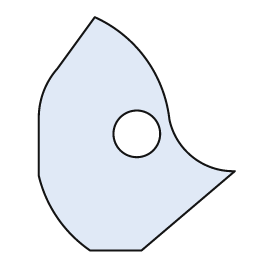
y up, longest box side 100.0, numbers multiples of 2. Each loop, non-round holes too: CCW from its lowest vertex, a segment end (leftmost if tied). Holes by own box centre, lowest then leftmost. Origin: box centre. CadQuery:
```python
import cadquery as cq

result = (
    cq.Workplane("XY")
    .moveTo(-20.0, -50.0)
    .lineTo(2.0, -50.0)
    .lineTo(42.0, -16.0)
    .threePointArc((24.0, -10.0), (14.0, 6.0))
    .threePointArc((4.0, 32.0), (-18.0, 50.0))
    .lineTo(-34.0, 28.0)
    .threePointArc((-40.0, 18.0), (-42.0, 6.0))
    .lineTo(-42.0, -18.0)
    .threePointArc((-34.0, -36.0), (-20.0, -50.0))
    .close()
    .moveTo(0.0, 0.0)
    .circle(10.0)
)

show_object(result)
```